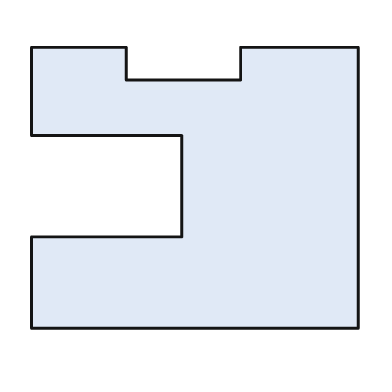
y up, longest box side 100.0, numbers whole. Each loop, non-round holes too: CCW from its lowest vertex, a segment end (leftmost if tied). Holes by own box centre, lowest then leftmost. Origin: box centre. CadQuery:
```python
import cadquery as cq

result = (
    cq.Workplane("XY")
    .moveTo(-50.0, -43.0)
    .lineTo(50.0, -43.0)
    .lineTo(50.0, 43.0)
    .lineTo(14.0, 43.0)
    .lineTo(14.0, 33.0)
    .lineTo(-21.0, 33.0)
    .lineTo(-21.0, 43.0)
    .lineTo(-50.0, 43.0)
    .lineTo(-50.0, 16.0)
    .lineTo(-4.0, 16.0)
    .lineTo(-4.0, -15.0)
    .lineTo(-50.0, -15.0)
    .close()
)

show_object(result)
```